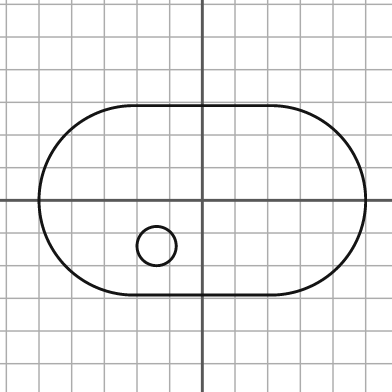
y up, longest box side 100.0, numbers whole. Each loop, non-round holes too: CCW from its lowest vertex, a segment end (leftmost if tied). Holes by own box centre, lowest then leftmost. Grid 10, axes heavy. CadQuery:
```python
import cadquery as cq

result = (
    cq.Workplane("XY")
    .moveTo(-21.0, -29.0)
    .lineTo(21.0, -29.0)
    .threePointArc((50.0, 0.0), (21.0, 29.0))
    .lineTo(-21.0, 29.0)
    .threePointArc((-50.0, 0.0), (-21.0, -29.0))
    .close()
    .moveTo(-14.0, -14.0)
    .circle(6.0)
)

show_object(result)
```